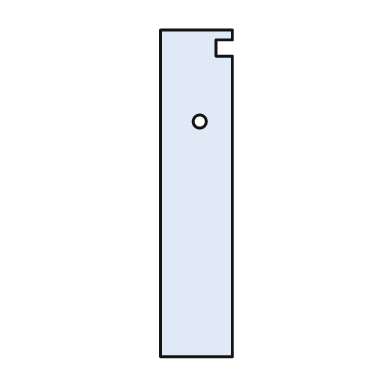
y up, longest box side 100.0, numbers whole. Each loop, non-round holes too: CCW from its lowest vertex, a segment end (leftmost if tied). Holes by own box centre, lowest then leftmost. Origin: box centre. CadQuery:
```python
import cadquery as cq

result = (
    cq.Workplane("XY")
    .moveTo(-11.0, -50.0)
    .lineTo(11.0, -50.0)
    .lineTo(11.0, 42.0)
    .lineTo(6.0, 42.0)
    .lineTo(6.0, 47.0)
    .lineTo(11.0, 47.0)
    .lineTo(11.0, 50.0)
    .lineTo(-11.0, 50.0)
    .close()
    .moveTo(1.0, 22.0)
    .circle(2.0)
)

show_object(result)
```